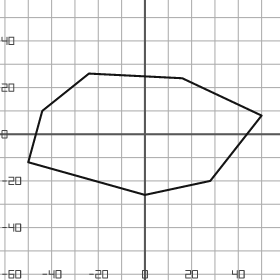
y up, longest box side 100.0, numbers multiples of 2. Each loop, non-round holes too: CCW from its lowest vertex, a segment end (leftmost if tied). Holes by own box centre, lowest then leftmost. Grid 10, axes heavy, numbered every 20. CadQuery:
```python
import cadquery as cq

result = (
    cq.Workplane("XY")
    .moveTo(0.0, -26.0)
    .lineTo(28.0, -20.0)
    .lineTo(50.0, 8.0)
    .lineTo(16.0, 24.0)
    .lineTo(-24.0, 26.0)
    .lineTo(-44.0, 10.0)
    .lineTo(-50.0, -12.0)
    .close()
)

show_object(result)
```